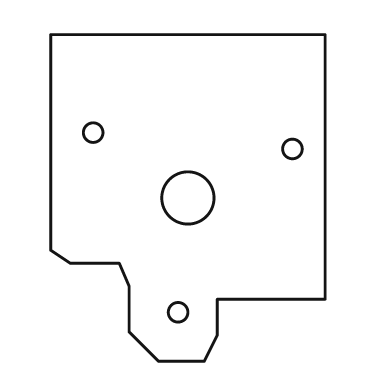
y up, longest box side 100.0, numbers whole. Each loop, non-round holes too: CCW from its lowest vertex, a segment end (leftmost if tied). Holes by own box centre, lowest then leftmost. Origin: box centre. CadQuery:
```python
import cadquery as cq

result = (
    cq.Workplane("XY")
    .moveTo(-9.0, -50.0)
    .lineTo(5.0, -50.0)
    .lineTo(9.0, -42.0)
    .lineTo(9.0, -31.0)
    .lineTo(42.0, -31.0)
    .lineTo(42.0, 50.0)
    .lineTo(-42.0, 50.0)
    .lineTo(-42.0, -16.0)
    .lineTo(-36.0, -20.0)
    .lineTo(-21.0, -20.0)
    .lineTo(-18.0, -27.0)
    .lineTo(-18.0, -41.0)
    .close()
    .moveTo(-3.0, -35.0)
    .circle(3.0)
    .moveTo(0.0, 0.0)
    .circle(8.0)
    .moveTo(32.0, 15.0)
    .circle(3.0)
    .moveTo(-29.0, 20.0)
    .circle(3.0)
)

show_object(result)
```